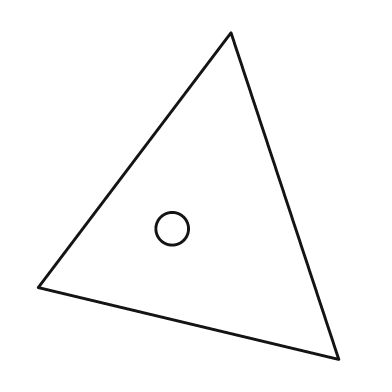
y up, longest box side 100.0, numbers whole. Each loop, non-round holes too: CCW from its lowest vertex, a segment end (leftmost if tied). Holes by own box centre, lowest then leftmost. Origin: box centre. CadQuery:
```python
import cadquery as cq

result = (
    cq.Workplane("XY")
    .moveTo(46.0, -50.0)
    .lineTo(13.0, 50.0)
    .lineTo(-46.0, -28.0)
    .close()
    .moveTo(-5.0, -10.0)
    .circle(5.0)
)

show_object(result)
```